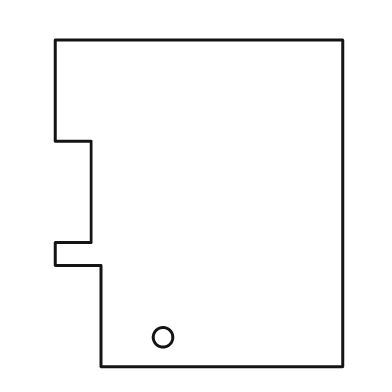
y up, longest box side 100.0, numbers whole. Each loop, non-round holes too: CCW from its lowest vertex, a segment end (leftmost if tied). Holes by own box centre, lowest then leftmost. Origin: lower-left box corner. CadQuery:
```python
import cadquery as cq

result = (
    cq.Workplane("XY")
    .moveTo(14.0, 0.0)
    .lineTo(88.0, 0.0)
    .lineTo(88.0, 100.0)
    .lineTo(0.0, 100.0)
    .lineTo(0.0, 69.0)
    .lineTo(11.0, 69.0)
    .lineTo(11.0, 38.0)
    .lineTo(0.0, 38.0)
    .lineTo(0.0, 31.0)
    .lineTo(14.0, 31.0)
    .close()
    .moveTo(33.0, 9.0)
    .circle(3.0)
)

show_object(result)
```